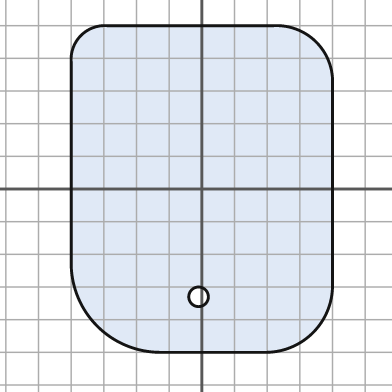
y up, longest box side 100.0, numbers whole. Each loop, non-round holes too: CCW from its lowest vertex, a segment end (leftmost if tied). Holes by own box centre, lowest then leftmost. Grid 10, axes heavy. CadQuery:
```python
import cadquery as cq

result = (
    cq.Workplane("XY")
    .moveTo(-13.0, -50.0)
    .lineTo(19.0, -50.0)
    .threePointArc((34.0, -44.0), (40.0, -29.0))
    .lineTo(40.0, 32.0)
    .threePointArc((35.0, 45.0), (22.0, 50.0))
    .lineTo(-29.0, 50.0)
    .threePointArc((-37.0, 47.0), (-40.0, 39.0))
    .lineTo(-40.0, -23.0)
    .threePointArc((-32.0, -42.0), (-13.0, -50.0))
    .close()
    .moveTo(-1.0, -33.0)
    .circle(3.0)
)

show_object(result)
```